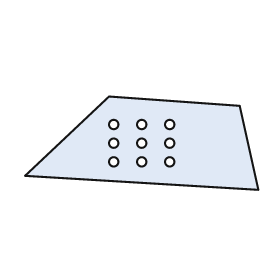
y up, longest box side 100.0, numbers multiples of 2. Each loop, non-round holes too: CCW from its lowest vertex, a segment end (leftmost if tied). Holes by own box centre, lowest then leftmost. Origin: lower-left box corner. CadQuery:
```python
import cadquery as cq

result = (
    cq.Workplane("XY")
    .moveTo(100.0, 0.0)
    .lineTo(92.0, 36.0)
    .lineTo(36.0, 40.0)
    .lineTo(0.0, 6.0)
    .close()
    .moveTo(38.0, 12.0)
    .circle(2.0)
    .moveTo(50.0, 12.0)
    .circle(2.0)
    .moveTo(62.0, 12.0)
    .circle(2.0)
    .moveTo(38.0, 20.0)
    .circle(2.0)
    .moveTo(50.0, 20.0)
    .circle(2.0)
    .moveTo(62.0, 20.0)
    .circle(2.0)
    .moveTo(38.0, 28.0)
    .circle(2.0)
    .moveTo(50.0, 28.0)
    .circle(2.0)
    .moveTo(62.0, 28.0)
    .circle(2.0)
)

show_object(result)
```